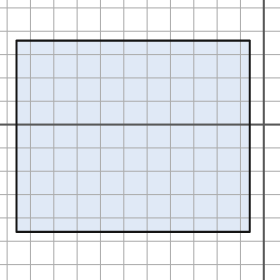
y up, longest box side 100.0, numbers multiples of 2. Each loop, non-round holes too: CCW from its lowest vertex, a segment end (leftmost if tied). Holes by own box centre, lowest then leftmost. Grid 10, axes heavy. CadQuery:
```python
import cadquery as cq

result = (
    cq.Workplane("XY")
    .moveTo(-106.0, -46.0)
    .lineTo(-6.0, -46.0)
    .lineTo(-6.0, 36.0)
    .lineTo(-106.0, 36.0)
    .close()
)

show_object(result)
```